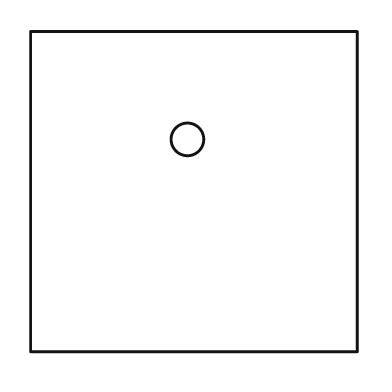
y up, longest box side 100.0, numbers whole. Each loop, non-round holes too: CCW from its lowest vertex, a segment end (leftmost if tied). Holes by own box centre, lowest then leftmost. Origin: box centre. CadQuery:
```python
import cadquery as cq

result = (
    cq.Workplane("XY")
    .moveTo(-50.0, -49.0)
    .lineTo(50.0, -49.0)
    .lineTo(50.0, 49.0)
    .lineTo(-50.0, 49.0)
    .close()
    .moveTo(-2.0, 16.0)
    .circle(5.0)
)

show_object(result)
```